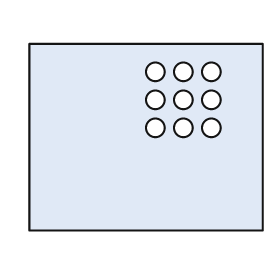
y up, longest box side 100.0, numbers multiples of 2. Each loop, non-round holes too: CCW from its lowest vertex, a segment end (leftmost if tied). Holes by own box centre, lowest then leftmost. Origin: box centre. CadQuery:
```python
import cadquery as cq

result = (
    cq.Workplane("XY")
    .moveTo(-50.0, -40.0)
    .lineTo(50.0, -40.0)
    .lineTo(50.0, 40.0)
    .lineTo(-50.0, 40.0)
    .close()
    .moveTo(4.0, 4.0)
    .circle(4.0)
    .moveTo(16.0, 4.0)
    .circle(4.0)
    .moveTo(28.0, 4.0)
    .circle(4.0)
    .moveTo(4.0, 16.0)
    .circle(4.0)
    .moveTo(16.0, 16.0)
    .circle(4.0)
    .moveTo(28.0, 16.0)
    .circle(4.0)
    .moveTo(4.0, 28.0)
    .circle(4.0)
    .moveTo(16.0, 28.0)
    .circle(4.0)
    .moveTo(28.0, 28.0)
    .circle(4.0)
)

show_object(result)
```